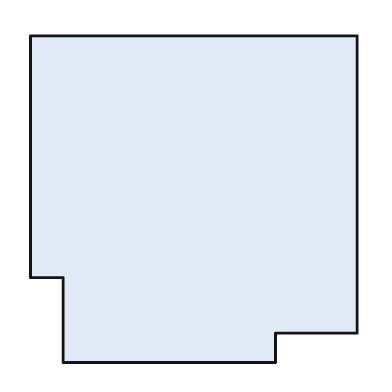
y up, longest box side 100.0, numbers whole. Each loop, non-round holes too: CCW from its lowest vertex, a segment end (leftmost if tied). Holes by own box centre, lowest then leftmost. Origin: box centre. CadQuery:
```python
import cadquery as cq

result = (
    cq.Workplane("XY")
    .moveTo(-40.0, -50.0)
    .lineTo(25.0, -50.0)
    .lineTo(25.0, -41.0)
    .lineTo(50.0, -41.0)
    .lineTo(50.0, 50.0)
    .lineTo(-50.0, 50.0)
    .lineTo(-50.0, -24.0)
    .lineTo(-40.0, -24.0)
    .close()
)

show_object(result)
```